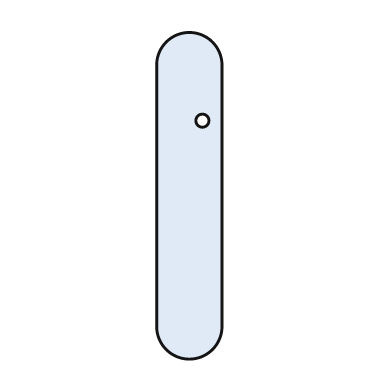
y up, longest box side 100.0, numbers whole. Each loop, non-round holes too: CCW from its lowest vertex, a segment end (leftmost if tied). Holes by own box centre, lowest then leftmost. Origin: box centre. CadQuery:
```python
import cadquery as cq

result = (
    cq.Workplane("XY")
    .moveTo(-10.0, -40.0)
    .threePointArc((0.0, -50.0), (10.0, -40.0))
    .lineTo(10.0, 40.0)
    .threePointArc((0.0, 50.0), (-10.0, 40.0))
    .close()
    .moveTo(4.0, 23.0)
    .circle(2.0)
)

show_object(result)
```